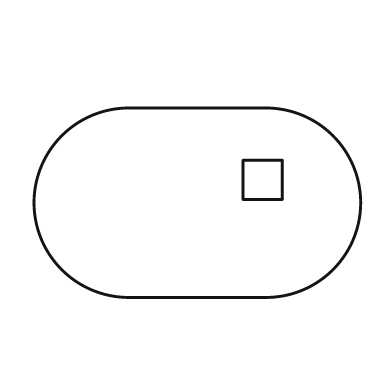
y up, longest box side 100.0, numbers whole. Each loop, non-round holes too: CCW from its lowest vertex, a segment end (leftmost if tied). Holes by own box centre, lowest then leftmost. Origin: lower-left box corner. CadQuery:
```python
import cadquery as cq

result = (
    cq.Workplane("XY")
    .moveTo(29.0, 0.0)
    .lineTo(71.0, 0.0)
    .threePointArc((100.0, 29.0), (71.0, 58.0))
    .lineTo(29.0, 58.0)
    .threePointArc((0.0, 29.0), (29.0, 0.0))
    .close()
    .moveTo(64.0, 30.0)
    .lineTo(76.0, 30.0)
    .lineTo(76.0, 42.0)
    .lineTo(64.0, 42.0)
    .close()
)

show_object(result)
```